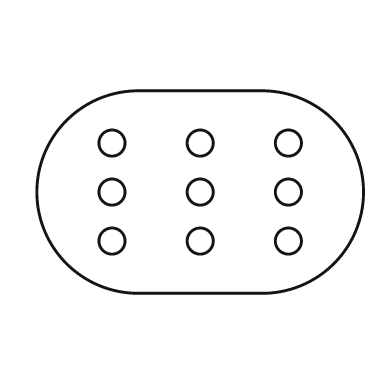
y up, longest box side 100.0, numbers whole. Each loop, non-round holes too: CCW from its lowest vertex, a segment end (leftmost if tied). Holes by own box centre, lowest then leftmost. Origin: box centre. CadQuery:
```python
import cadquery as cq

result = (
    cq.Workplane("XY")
    .moveTo(-19.0, -31.0)
    .lineTo(19.0, -31.0)
    .threePointArc((50.0, 0.0), (19.0, 31.0))
    .lineTo(-19.0, 31.0)
    .threePointArc((-50.0, 0.0), (-19.0, -31.0))
    .close()
    .moveTo(-27.0, -15.0)
    .circle(4.0)
    .moveTo(0.0, -15.0)
    .circle(4.0)
    .moveTo(27.0, -15.0)
    .circle(4.0)
    .moveTo(-27.0, 0.0)
    .circle(4.0)
    .moveTo(0.0, 0.0)
    .circle(4.0)
    .moveTo(27.0, 0.0)
    .circle(4.0)
    .moveTo(-27.0, 15.0)
    .circle(4.0)
    .moveTo(0.0, 15.0)
    .circle(4.0)
    .moveTo(27.0, 15.0)
    .circle(4.0)
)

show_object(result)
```